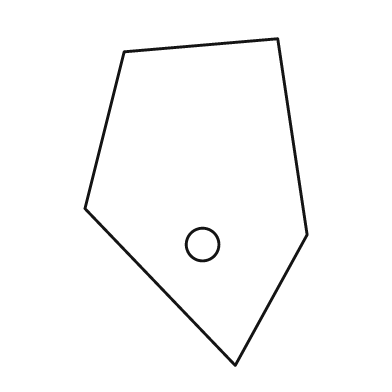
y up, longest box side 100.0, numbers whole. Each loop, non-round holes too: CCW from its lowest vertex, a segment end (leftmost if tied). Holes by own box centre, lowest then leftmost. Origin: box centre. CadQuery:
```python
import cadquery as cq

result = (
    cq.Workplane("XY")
    .moveTo(12.0, -50.0)
    .lineTo(34.0, -10.0)
    .lineTo(25.0, 50.0)
    .lineTo(-22.0, 46.0)
    .lineTo(-34.0, -2.0)
    .close()
    .moveTo(2.0, -13.0)
    .circle(5.0)
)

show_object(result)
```